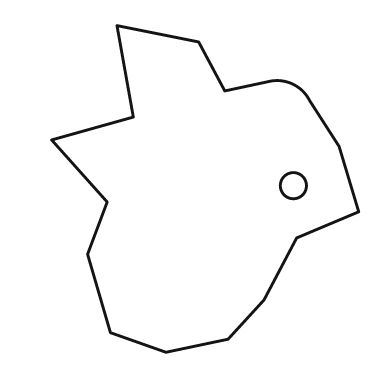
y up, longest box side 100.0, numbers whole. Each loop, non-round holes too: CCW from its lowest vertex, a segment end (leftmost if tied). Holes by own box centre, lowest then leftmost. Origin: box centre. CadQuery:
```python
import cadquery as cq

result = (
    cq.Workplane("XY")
    .moveTo(-12.0, -50.0)
    .lineTo(7.0, -46.0)
    .lineTo(18.0, -34.0)
    .lineTo(28.0, -15.0)
    .lineTo(47.0, -7.0)
    .lineTo(41.0, 13.0)
    .lineTo(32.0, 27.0)
    .threePointArc((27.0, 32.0), (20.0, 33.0))
    .lineTo(6.0, 30.0)
    .lineTo(-2.0, 45.0)
    .lineTo(-27.0, 50.0)
    .lineTo(-22.0, 22.0)
    .lineTo(-47.0, 15.0)
    .lineTo(-30.0, -4.0)
    .lineTo(-36.0, -20.0)
    .lineTo(-29.0, -44.0)
    .close()
    .moveTo(27.0, 1.0)
    .circle(4.0)
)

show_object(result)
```